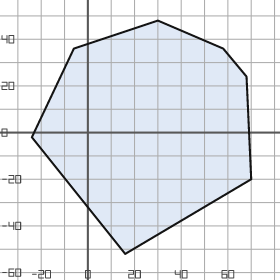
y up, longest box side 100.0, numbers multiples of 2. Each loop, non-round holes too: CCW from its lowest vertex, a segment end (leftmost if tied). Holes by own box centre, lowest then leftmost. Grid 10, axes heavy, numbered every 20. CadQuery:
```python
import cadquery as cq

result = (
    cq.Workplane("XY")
    .moveTo(16.0, -52.0)
    .lineTo(70.0, -20.0)
    .lineTo(68.0, 24.0)
    .lineTo(58.0, 36.0)
    .lineTo(30.0, 48.0)
    .lineTo(-6.0, 36.0)
    .lineTo(-24.0, -2.0)
    .close()
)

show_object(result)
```